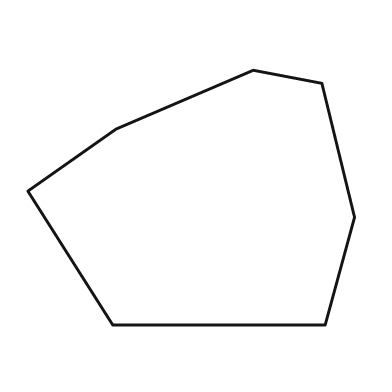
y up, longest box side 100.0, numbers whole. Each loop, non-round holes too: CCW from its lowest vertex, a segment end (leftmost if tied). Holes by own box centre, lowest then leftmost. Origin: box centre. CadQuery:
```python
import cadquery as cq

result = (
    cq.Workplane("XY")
    .moveTo(-24.0, -39.0)
    .lineTo(41.0, -39.0)
    .lineTo(50.0, -6.0)
    .lineTo(40.0, 35.0)
    .lineTo(19.0, 39.0)
    .lineTo(-23.0, 21.0)
    .lineTo(-50.0, 2.0)
    .close()
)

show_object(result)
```